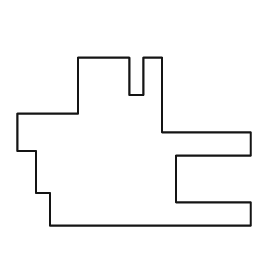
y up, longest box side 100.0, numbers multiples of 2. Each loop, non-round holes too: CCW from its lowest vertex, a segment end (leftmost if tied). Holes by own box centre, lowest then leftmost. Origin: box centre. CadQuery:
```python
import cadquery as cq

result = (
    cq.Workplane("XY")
    .moveTo(-36.0, -36.0)
    .lineTo(50.0, -36.0)
    .lineTo(50.0, -26.0)
    .lineTo(18.0, -26.0)
    .lineTo(18.0, -6.0)
    .lineTo(50.0, -6.0)
    .lineTo(50.0, 4.0)
    .lineTo(12.0, 4.0)
    .lineTo(12.0, 36.0)
    .lineTo(4.0, 36.0)
    .lineTo(4.0, 20.0)
    .lineTo(-2.0, 20.0)
    .lineTo(-2.0, 36.0)
    .lineTo(-24.0, 36.0)
    .lineTo(-24.0, 12.0)
    .lineTo(-50.0, 12.0)
    .lineTo(-50.0, -4.0)
    .lineTo(-42.0, -4.0)
    .lineTo(-42.0, -22.0)
    .lineTo(-36.0, -22.0)
    .close()
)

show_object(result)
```